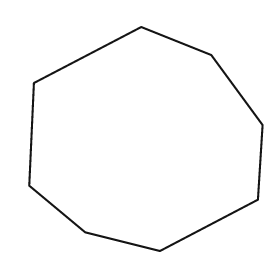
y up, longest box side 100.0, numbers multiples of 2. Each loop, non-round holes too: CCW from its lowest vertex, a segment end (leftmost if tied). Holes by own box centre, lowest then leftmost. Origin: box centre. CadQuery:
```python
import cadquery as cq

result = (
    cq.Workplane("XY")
    .moveTo(6.0, -48.0)
    .lineTo(48.0, -26.0)
    .lineTo(50.0, 6.0)
    .lineTo(28.0, 36.0)
    .lineTo(-2.0, 48.0)
    .lineTo(-48.0, 24.0)
    .lineTo(-50.0, -20.0)
    .lineTo(-26.0, -40.0)
    .close()
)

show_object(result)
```